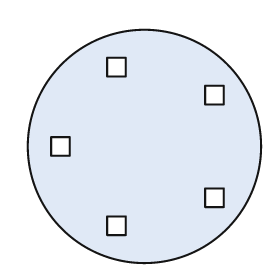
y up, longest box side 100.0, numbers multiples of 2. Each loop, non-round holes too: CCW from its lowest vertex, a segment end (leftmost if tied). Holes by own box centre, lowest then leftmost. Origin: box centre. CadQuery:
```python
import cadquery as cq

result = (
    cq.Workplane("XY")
    .moveTo(0.0, 0.0)
    .circle(50.0)
    .moveTo(-16.0, -38.0)
    .lineTo(-8.0, -38.0)
    .lineTo(-8.0, -30.0)
    .lineTo(-16.0, -30.0)
    .close()
    .moveTo(26.0, -26.0)
    .lineTo(34.0, -26.0)
    .lineTo(34.0, -18.0)
    .lineTo(26.0, -18.0)
    .close()
    .moveTo(-40.0, -4.0)
    .lineTo(-32.0, -4.0)
    .lineTo(-32.0, 4.0)
    .lineTo(-40.0, 4.0)
    .close()
    .moveTo(26.0, 18.0)
    .lineTo(34.0, 18.0)
    .lineTo(34.0, 26.0)
    .lineTo(26.0, 26.0)
    .close()
    .moveTo(-16.0, 30.0)
    .lineTo(-8.0, 30.0)
    .lineTo(-8.0, 38.0)
    .lineTo(-16.0, 38.0)
    .close()
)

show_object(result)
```